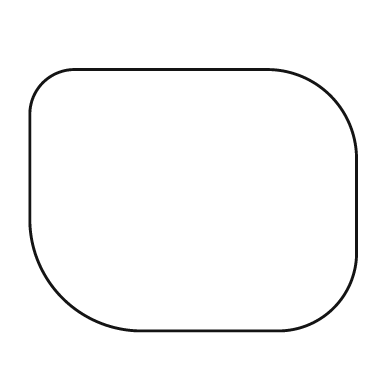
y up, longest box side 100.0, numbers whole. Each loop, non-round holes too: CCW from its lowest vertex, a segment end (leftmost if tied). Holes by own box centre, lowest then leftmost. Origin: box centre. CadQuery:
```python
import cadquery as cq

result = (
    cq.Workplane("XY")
    .moveTo(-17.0, -40.0)
    .lineTo(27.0, -40.0)
    .threePointArc((43.0, -33.0), (50.0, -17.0))
    .lineTo(50.0, 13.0)
    .threePointArc((42.0, 32.0), (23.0, 40.0))
    .lineTo(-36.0, 40.0)
    .threePointArc((-46.0, 36.0), (-50.0, 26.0))
    .lineTo(-50.0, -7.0)
    .threePointArc((-40.0, -30.0), (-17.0, -40.0))
    .close()
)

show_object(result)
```